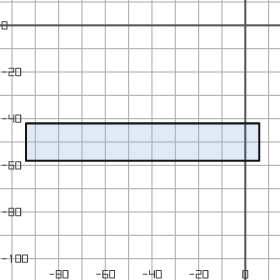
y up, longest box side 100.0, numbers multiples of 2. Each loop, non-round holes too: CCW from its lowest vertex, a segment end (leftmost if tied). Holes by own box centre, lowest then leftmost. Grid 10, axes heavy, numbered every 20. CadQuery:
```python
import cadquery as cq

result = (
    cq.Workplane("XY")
    .moveTo(-94.0, -58.0)
    .lineTo(6.0, -58.0)
    .lineTo(6.0, -42.0)
    .lineTo(-94.0, -42.0)
    .close()
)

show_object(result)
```